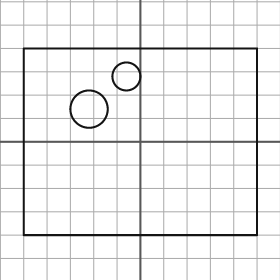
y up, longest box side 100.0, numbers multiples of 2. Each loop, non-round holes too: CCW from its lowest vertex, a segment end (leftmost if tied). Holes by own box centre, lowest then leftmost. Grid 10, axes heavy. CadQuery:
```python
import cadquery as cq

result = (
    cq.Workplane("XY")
    .moveTo(-50.0, -40.0)
    .lineTo(50.0, -40.0)
    .lineTo(50.0, 40.0)
    .lineTo(-50.0, 40.0)
    .close()
    .moveTo(-22.0, 14.0)
    .circle(8.0)
    .moveTo(-6.0, 28.0)
    .circle(6.0)
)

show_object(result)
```